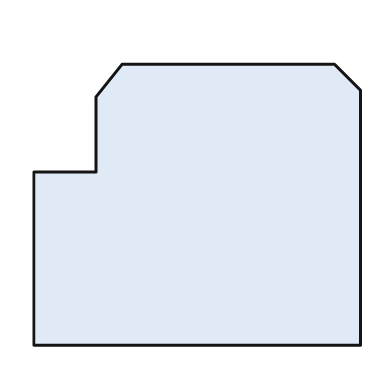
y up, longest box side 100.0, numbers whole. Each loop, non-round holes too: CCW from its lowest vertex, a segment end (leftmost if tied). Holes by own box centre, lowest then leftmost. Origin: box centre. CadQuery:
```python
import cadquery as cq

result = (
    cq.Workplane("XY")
    .moveTo(-50.0, -43.0)
    .lineTo(50.0, -43.0)
    .lineTo(50.0, 35.0)
    .lineTo(42.0, 43.0)
    .lineTo(-23.0, 43.0)
    .lineTo(-31.0, 33.0)
    .lineTo(-31.0, 10.0)
    .lineTo(-50.0, 10.0)
    .close()
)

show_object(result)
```